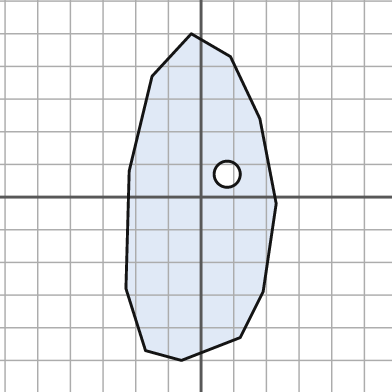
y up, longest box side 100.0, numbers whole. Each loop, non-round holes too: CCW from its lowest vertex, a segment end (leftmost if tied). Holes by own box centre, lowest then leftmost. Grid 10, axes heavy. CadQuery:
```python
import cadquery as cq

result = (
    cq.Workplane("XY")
    .moveTo(-6.0, -50.0)
    .lineTo(12.0, -43.0)
    .lineTo(19.0, -29.0)
    .lineTo(23.0, -2.0)
    .lineTo(18.0, 24.0)
    .lineTo(9.0, 43.0)
    .lineTo(-3.0, 50.0)
    .lineTo(-15.0, 37.0)
    .lineTo(-22.0, 8.0)
    .lineTo(-23.0, -28.0)
    .lineTo(-17.0, -47.0)
    .close()
    .moveTo(8.0, 7.0)
    .circle(4.0)
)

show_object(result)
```